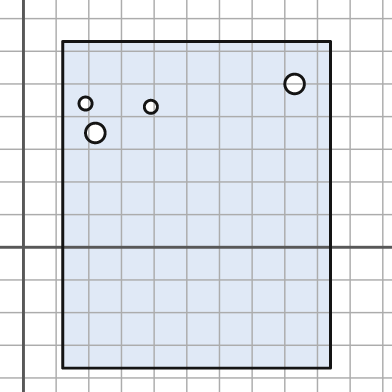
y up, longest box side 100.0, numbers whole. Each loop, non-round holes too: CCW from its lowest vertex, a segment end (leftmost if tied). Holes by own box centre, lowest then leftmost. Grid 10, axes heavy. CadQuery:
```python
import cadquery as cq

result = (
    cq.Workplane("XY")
    .moveTo(12.0, -37.0)
    .lineTo(94.0, -37.0)
    .lineTo(94.0, 63.0)
    .lineTo(12.0, 63.0)
    .close()
    .moveTo(22.0, 35.0)
    .circle(3.0)
    .moveTo(39.0, 43.0)
    .circle(2.0)
    .moveTo(19.0, 44.0)
    .circle(2.0)
    .moveTo(83.0, 50.0)
    .circle(3.0)
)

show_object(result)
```